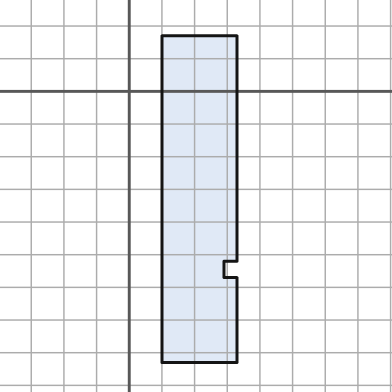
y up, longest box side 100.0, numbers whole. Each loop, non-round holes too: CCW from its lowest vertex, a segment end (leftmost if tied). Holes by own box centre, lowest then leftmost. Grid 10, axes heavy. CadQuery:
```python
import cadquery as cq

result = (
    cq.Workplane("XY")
    .moveTo(10.0, -83.0)
    .lineTo(33.0, -83.0)
    .lineTo(33.0, -57.0)
    .lineTo(29.0, -57.0)
    .lineTo(29.0, -52.0)
    .lineTo(33.0, -52.0)
    .lineTo(33.0, 17.0)
    .lineTo(10.0, 17.0)
    .close()
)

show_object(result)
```